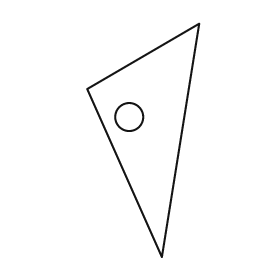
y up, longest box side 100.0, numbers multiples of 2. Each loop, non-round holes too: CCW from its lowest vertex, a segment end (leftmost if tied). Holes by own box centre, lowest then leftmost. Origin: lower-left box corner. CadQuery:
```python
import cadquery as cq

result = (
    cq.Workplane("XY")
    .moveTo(32.0, 0.0)
    .lineTo(48.0, 100.0)
    .lineTo(0.0, 72.0)
    .close()
    .moveTo(18.0, 60.0)
    .circle(6.0)
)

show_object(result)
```